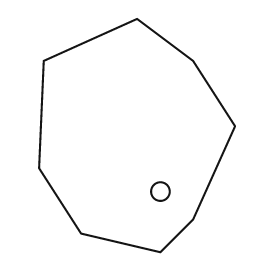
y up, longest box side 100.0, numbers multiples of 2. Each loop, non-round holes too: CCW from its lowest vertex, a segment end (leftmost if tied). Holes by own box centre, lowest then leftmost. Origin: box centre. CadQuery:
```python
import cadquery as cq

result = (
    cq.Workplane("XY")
    .moveTo(10.0, -50.0)
    .lineTo(24.0, -36.0)
    .lineTo(42.0, 4.0)
    .lineTo(24.0, 32.0)
    .lineTo(0.0, 50.0)
    .lineTo(-40.0, 32.0)
    .lineTo(-42.0, -14.0)
    .lineTo(-24.0, -42.0)
    .close()
    .moveTo(10.0, -24.0)
    .circle(4.0)
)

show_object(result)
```